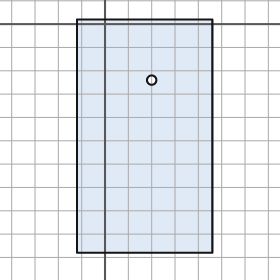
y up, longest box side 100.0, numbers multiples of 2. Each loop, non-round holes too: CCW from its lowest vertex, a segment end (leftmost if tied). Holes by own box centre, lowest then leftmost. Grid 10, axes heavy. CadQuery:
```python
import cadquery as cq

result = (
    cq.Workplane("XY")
    .moveTo(-12.0, -98.0)
    .lineTo(46.0, -98.0)
    .lineTo(46.0, 2.0)
    .lineTo(-12.0, 2.0)
    .close()
    .moveTo(20.0, -24.0)
    .circle(2.0)
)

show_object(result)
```